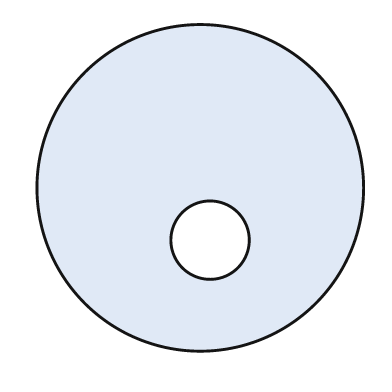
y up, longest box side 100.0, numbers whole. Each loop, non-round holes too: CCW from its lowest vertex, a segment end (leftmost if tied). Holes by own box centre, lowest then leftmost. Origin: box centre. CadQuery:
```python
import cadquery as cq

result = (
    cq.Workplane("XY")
    .moveTo(0.0, 0.0)
    .circle(50.0)
    .moveTo(3.0, -16.0)
    .circle(12.0)
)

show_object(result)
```